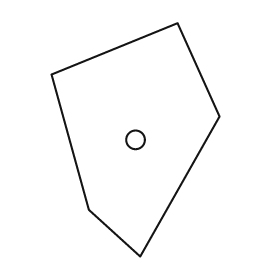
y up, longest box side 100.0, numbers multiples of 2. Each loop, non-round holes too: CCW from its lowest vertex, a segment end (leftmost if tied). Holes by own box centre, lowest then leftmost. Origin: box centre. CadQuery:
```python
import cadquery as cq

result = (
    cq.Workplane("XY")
    .moveTo(2.0, -50.0)
    .lineTo(36.0, 10.0)
    .lineTo(18.0, 50.0)
    .lineTo(-36.0, 28.0)
    .lineTo(-20.0, -30.0)
    .close()
    .moveTo(0.0, 0.0)
    .circle(4.0)
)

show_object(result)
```